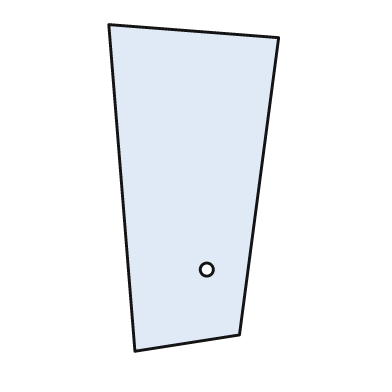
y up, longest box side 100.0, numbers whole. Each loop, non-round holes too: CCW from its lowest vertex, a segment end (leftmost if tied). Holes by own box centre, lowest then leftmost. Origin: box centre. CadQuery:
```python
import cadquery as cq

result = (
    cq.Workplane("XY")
    .moveTo(-18.0, -50.0)
    .lineTo(14.0, -45.0)
    .lineTo(26.0, 46.0)
    .lineTo(-26.0, 50.0)
    .close()
    .moveTo(4.0, -25.0)
    .circle(2.0)
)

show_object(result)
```